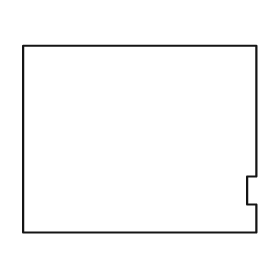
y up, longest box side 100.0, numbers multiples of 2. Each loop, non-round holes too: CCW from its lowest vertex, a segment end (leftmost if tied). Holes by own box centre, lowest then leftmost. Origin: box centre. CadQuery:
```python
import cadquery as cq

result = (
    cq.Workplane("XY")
    .moveTo(-50.0, -40.0)
    .lineTo(50.0, -40.0)
    .lineTo(50.0, -28.0)
    .lineTo(46.0, -28.0)
    .lineTo(46.0, -16.0)
    .lineTo(50.0, -16.0)
    .lineTo(50.0, 40.0)
    .lineTo(-50.0, 40.0)
    .close()
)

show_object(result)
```